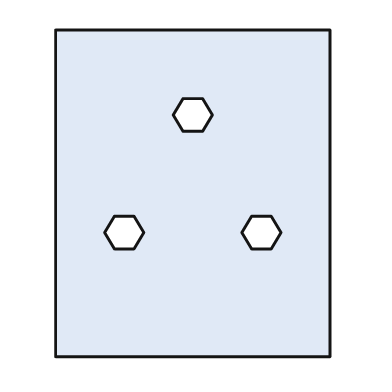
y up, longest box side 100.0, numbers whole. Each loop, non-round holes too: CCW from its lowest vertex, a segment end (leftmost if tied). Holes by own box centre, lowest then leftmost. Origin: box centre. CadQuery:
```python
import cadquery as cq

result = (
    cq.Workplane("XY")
    .moveTo(-42.0, -50.0)
    .lineTo(42.0, -50.0)
    .lineTo(42.0, 50.0)
    .lineTo(-42.0, 50.0)
    .close()
    .moveTo(-24.0, -17.0)
    .lineTo(-18.0, -17.0)
    .lineTo(-15.0, -12.0)
    .lineTo(-18.0, -7.0)
    .lineTo(-24.0, -7.0)
    .lineTo(-27.0, -12.0)
    .close()
    .moveTo(18.0, -17.0)
    .lineTo(24.0, -17.0)
    .lineTo(27.0, -12.0)
    .lineTo(24.0, -7.0)
    .lineTo(18.0, -7.0)
    .lineTo(15.0, -12.0)
    .close()
    .moveTo(-3.0, 19.0)
    .lineTo(3.0, 19.0)
    .lineTo(6.0, 24.0)
    .lineTo(3.0, 29.0)
    .lineTo(-3.0, 29.0)
    .lineTo(-6.0, 24.0)
    .close()
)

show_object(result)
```